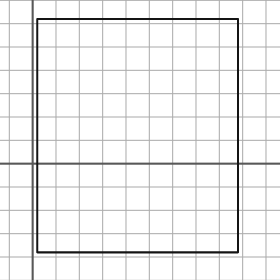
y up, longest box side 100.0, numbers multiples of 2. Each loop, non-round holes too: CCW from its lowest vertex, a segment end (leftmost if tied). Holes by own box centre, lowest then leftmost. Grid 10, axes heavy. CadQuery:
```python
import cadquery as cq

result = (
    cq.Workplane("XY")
    .moveTo(2.0, -38.0)
    .lineTo(88.0, -38.0)
    .lineTo(88.0, 62.0)
    .lineTo(2.0, 62.0)
    .close()
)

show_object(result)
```